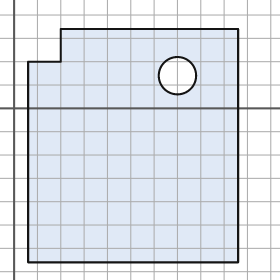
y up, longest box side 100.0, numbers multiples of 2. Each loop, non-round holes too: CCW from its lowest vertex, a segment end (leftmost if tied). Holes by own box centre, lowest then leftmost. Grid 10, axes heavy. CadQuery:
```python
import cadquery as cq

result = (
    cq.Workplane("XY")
    .moveTo(6.0, -66.0)
    .lineTo(96.0, -66.0)
    .lineTo(96.0, 34.0)
    .lineTo(20.0, 34.0)
    .lineTo(20.0, 20.0)
    .lineTo(6.0, 20.0)
    .close()
    .moveTo(70.0, 14.0)
    .circle(8.0)
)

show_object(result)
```